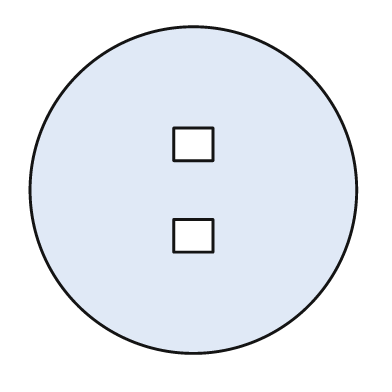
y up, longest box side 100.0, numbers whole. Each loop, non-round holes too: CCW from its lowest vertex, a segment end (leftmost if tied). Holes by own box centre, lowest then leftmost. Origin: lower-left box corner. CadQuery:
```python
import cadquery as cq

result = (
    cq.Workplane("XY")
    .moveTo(50.0, 50.0)
    .circle(50.0)
    .moveTo(44.0, 31.0)
    .lineTo(56.0, 31.0)
    .lineTo(56.0, 41.0)
    .lineTo(44.0, 41.0)
    .close()
    .moveTo(44.0, 59.0)
    .lineTo(56.0, 59.0)
    .lineTo(56.0, 69.0)
    .lineTo(44.0, 69.0)
    .close()
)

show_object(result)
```